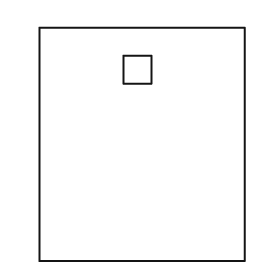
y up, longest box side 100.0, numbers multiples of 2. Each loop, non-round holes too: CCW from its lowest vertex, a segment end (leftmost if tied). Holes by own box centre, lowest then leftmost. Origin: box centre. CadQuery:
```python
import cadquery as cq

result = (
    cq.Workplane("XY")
    .moveTo(-44.0, -50.0)
    .lineTo(44.0, -50.0)
    .lineTo(44.0, 50.0)
    .lineTo(-44.0, 50.0)
    .close()
    .moveTo(-8.0, 26.0)
    .lineTo(4.0, 26.0)
    .lineTo(4.0, 38.0)
    .lineTo(-8.0, 38.0)
    .close()
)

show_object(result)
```